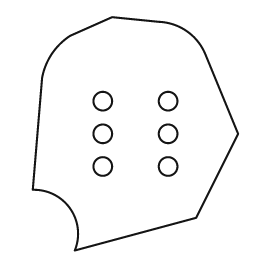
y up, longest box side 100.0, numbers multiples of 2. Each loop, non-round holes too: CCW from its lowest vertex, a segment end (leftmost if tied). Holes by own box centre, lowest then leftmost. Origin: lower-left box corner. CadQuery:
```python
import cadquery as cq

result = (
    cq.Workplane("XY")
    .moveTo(18.0, 0.0)
    .lineTo(70.0, 14.0)
    .lineTo(88.0, 50.0)
    .lineTo(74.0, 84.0)
    .threePointArc((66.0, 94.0), (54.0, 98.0))
    .lineTo(34.0, 100.0)
    .lineTo(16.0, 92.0)
    .threePointArc((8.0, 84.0), (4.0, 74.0))
    .lineTo(0.0, 26.0)
    .threePointArc((16.0, 18.0), (18.0, 0.0))
    .close()
    .moveTo(30.0, 36.0)
    .circle(4.0)
    .moveTo(58.0, 36.0)
    .circle(4.0)
    .moveTo(30.0, 50.0)
    .circle(4.0)
    .moveTo(58.0, 50.0)
    .circle(4.0)
    .moveTo(30.0, 64.0)
    .circle(4.0)
    .moveTo(58.0, 64.0)
    .circle(4.0)
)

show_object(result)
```